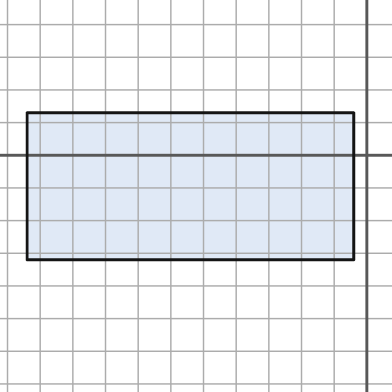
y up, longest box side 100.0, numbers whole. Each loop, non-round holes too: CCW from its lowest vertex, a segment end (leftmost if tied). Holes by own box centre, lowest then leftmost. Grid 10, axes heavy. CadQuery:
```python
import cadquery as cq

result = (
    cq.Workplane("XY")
    .moveTo(-104.0, -32.0)
    .lineTo(-4.0, -32.0)
    .lineTo(-4.0, 13.0)
    .lineTo(-104.0, 13.0)
    .close()
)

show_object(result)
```